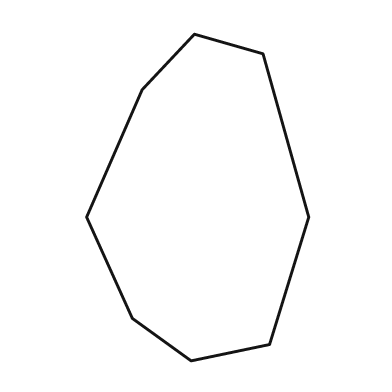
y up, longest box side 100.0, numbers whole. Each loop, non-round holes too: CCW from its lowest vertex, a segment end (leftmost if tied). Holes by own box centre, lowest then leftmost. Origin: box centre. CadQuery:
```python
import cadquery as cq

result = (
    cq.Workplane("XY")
    .moveTo(-2.0, -50.0)
    .lineTo(22.0, -45.0)
    .lineTo(34.0, -6.0)
    .lineTo(20.0, 44.0)
    .lineTo(-1.0, 50.0)
    .lineTo(-17.0, 33.0)
    .lineTo(-34.0, -6.0)
    .lineTo(-20.0, -37.0)
    .close()
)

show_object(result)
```